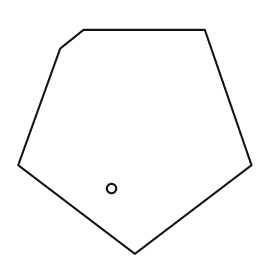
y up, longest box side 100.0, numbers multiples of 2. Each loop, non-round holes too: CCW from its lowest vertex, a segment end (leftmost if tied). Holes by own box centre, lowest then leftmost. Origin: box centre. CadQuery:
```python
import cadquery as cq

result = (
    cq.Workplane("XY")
    .moveTo(0.0, -48.0)
    .lineTo(50.0, -10.0)
    .lineTo(30.0, 48.0)
    .lineTo(-22.0, 48.0)
    .lineTo(-32.0, 40.0)
    .lineTo(-50.0, -10.0)
    .close()
    .moveTo(-10.0, -20.0)
    .circle(2.0)
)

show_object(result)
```